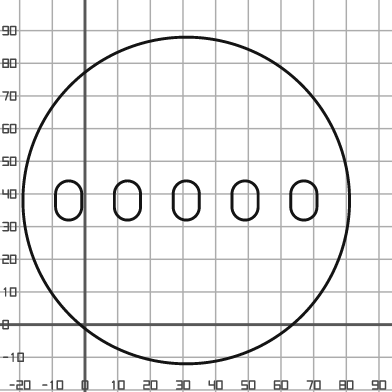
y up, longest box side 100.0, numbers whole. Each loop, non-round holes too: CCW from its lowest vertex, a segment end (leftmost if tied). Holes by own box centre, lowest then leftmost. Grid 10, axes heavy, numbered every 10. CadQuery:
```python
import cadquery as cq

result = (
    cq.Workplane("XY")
    .moveTo(31.0, 38.0)
    .circle(50.0)
    .moveTo(-9.0, 36.0)
    .threePointArc((-5.0, 32.0), (-1.0, 36.0))
    .lineTo(-1.0, 40.0)
    .threePointArc((-5.0, 44.0), (-9.0, 40.0))
    .close()
    .moveTo(9.0, 36.0)
    .threePointArc((13.0, 32.0), (17.0, 36.0))
    .lineTo(17.0, 40.0)
    .threePointArc((13.0, 44.0), (9.0, 40.0))
    .close()
    .moveTo(27.0, 36.0)
    .threePointArc((31.0, 32.0), (35.0, 36.0))
    .lineTo(35.0, 40.0)
    .threePointArc((31.0, 44.0), (27.0, 40.0))
    .close()
    .moveTo(45.0, 36.0)
    .threePointArc((49.0, 32.0), (53.0, 36.0))
    .lineTo(53.0, 40.0)
    .threePointArc((49.0, 44.0), (45.0, 40.0))
    .close()
    .moveTo(63.0, 36.0)
    .threePointArc((67.0, 32.0), (71.0, 36.0))
    .lineTo(71.0, 40.0)
    .threePointArc((67.0, 44.0), (63.0, 40.0))
    .close()
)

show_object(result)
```